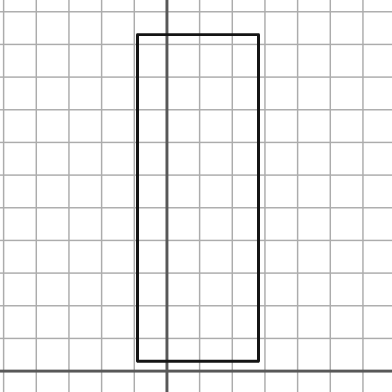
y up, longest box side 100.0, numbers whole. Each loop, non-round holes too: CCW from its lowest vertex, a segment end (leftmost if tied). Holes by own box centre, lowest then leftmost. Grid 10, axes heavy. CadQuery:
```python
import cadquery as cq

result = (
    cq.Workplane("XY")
    .moveTo(-9.0, 3.0)
    .lineTo(28.0, 3.0)
    .lineTo(28.0, 103.0)
    .lineTo(-9.0, 103.0)
    .close()
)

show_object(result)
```